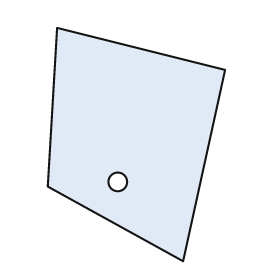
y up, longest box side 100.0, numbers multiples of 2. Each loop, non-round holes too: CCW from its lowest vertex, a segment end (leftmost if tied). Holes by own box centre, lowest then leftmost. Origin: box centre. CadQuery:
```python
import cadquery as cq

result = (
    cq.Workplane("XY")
    .moveTo(20.0, -50.0)
    .lineTo(38.0, 32.0)
    .lineTo(-34.0, 50.0)
    .lineTo(-38.0, -18.0)
    .close()
    .moveTo(-8.0, -16.0)
    .circle(4.0)
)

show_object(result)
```